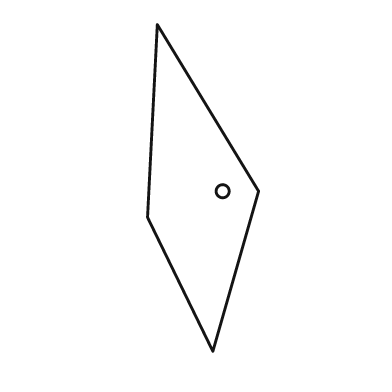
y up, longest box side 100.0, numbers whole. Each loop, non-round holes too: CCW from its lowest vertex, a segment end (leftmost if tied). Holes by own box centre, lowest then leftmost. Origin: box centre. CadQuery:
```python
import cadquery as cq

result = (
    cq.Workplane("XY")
    .moveTo(3.0, -50.0)
    .lineTo(17.0, -1.0)
    .lineTo(-14.0, 50.0)
    .lineTo(-17.0, -9.0)
    .close()
    .moveTo(6.0, -1.0)
    .circle(2.0)
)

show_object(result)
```